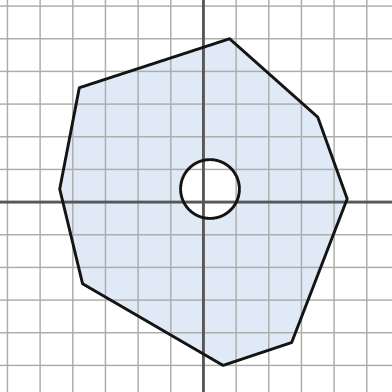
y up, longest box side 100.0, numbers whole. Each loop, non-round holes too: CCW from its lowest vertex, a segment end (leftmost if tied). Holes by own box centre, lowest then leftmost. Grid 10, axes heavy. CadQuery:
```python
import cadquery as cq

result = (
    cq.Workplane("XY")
    .moveTo(6.0, -50.0)
    .lineTo(27.0, -43.0)
    .lineTo(44.0, 1.0)
    .lineTo(35.0, 26.0)
    .lineTo(8.0, 50.0)
    .lineTo(-38.0, 35.0)
    .lineTo(-44.0, 4.0)
    .lineTo(-37.0, -25.0)
    .close()
    .moveTo(2.0, 4.0)
    .circle(9.0)
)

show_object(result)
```